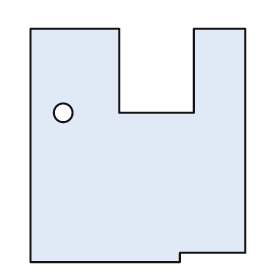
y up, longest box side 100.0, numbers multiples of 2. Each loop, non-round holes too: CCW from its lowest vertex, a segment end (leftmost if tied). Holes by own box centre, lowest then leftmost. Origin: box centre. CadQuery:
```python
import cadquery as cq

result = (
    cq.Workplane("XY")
    .moveTo(-46.0, -50.0)
    .lineTo(18.0, -50.0)
    .lineTo(18.0, -46.0)
    .lineTo(46.0, -46.0)
    .lineTo(46.0, 50.0)
    .lineTo(24.0, 50.0)
    .lineTo(24.0, 14.0)
    .lineTo(-8.0, 14.0)
    .lineTo(-8.0, 50.0)
    .lineTo(-46.0, 50.0)
    .close()
    .moveTo(-32.0, 14.0)
    .circle(4.0)
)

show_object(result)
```